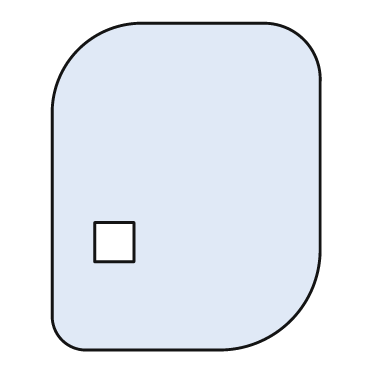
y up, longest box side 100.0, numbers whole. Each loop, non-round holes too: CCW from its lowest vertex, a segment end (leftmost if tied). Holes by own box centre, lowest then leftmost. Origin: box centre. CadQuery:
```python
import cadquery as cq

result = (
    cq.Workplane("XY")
    .moveTo(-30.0, -50.0)
    .lineTo(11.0, -50.0)
    .threePointArc((32.0, -41.0), (41.0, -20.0))
    .lineTo(41.0, 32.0)
    .threePointArc((36.0, 45.0), (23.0, 50.0))
    .lineTo(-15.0, 50.0)
    .threePointArc((-33.0, 42.0), (-41.0, 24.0))
    .lineTo(-41.0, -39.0)
    .threePointArc((-38.0, -47.0), (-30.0, -50.0))
    .close()
    .moveTo(-28.0, -23.0)
    .lineTo(-16.0, -23.0)
    .lineTo(-16.0, -11.0)
    .lineTo(-28.0, -11.0)
    .close()
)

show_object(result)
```